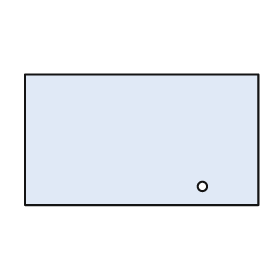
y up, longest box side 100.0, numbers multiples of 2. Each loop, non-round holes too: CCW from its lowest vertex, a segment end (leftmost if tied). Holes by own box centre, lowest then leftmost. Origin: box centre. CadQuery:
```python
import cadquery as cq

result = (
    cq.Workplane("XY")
    .moveTo(-50.0, -28.0)
    .lineTo(50.0, -28.0)
    .lineTo(50.0, 28.0)
    .lineTo(-50.0, 28.0)
    .close()
    .moveTo(26.0, -20.0)
    .circle(2.0)
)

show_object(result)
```